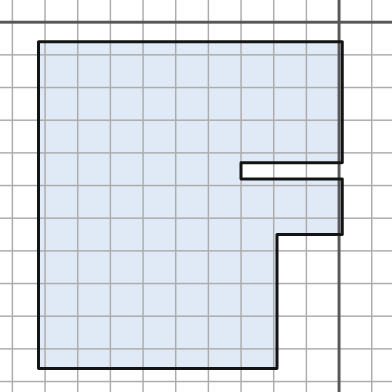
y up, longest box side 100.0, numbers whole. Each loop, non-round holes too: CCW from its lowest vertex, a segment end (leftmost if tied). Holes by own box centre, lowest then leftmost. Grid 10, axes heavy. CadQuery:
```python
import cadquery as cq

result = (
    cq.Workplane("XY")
    .moveTo(-92.0, -106.0)
    .lineTo(-19.0, -106.0)
    .lineTo(-19.0, -65.0)
    .lineTo(1.0, -65.0)
    .lineTo(1.0, -48.0)
    .lineTo(-30.0, -48.0)
    .lineTo(-30.0, -43.0)
    .lineTo(1.0, -43.0)
    .lineTo(1.0, -6.0)
    .lineTo(-92.0, -6.0)
    .close()
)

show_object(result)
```